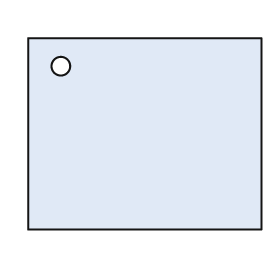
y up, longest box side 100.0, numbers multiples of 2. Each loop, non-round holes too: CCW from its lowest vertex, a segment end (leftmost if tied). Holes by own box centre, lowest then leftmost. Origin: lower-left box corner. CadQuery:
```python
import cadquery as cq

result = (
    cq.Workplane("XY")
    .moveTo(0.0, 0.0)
    .lineTo(100.0, 0.0)
    .lineTo(100.0, 82.0)
    .lineTo(0.0, 82.0)
    .close()
    .moveTo(14.0, 70.0)
    .circle(4.0)
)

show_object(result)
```